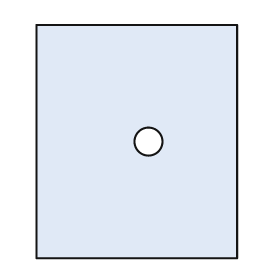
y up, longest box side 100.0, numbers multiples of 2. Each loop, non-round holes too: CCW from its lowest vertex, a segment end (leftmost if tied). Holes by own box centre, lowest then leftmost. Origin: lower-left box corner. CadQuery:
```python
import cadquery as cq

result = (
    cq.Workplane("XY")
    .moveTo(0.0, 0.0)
    .lineTo(86.0, 0.0)
    .lineTo(86.0, 100.0)
    .lineTo(0.0, 100.0)
    .close()
    .moveTo(48.0, 50.0)
    .circle(6.0)
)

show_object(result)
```